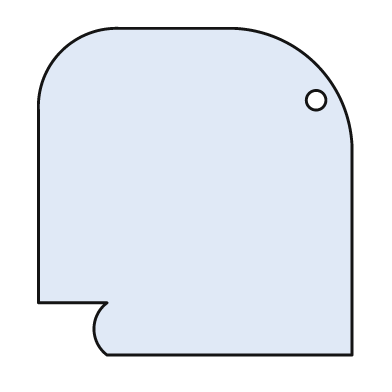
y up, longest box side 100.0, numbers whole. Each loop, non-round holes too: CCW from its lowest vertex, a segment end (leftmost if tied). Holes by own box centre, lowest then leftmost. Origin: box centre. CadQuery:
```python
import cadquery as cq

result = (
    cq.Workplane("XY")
    .moveTo(-27.0, -50.0)
    .lineTo(48.0, -50.0)
    .lineTo(48.0, 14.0)
    .threePointArc((37.0, 39.0), (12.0, 50.0))
    .lineTo(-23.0, 50.0)
    .threePointArc((-41.0, 43.0), (-48.0, 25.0))
    .lineTo(-48.0, -34.0)
    .lineTo(-27.0, -34.0)
    .threePointArc((-31.0, -42.0), (-27.0, -50.0))
    .close()
    .moveTo(37.0, 28.0)
    .circle(3.0)
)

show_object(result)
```